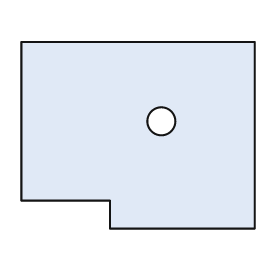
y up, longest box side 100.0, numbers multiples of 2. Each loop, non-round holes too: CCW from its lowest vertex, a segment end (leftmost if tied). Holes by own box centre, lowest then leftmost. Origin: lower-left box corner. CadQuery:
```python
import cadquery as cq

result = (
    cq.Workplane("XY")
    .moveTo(38.0, 0.0)
    .lineTo(100.0, 0.0)
    .lineTo(100.0, 80.0)
    .lineTo(0.0, 80.0)
    .lineTo(0.0, 12.0)
    .lineTo(38.0, 12.0)
    .close()
    .moveTo(60.0, 46.0)
    .circle(6.0)
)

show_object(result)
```